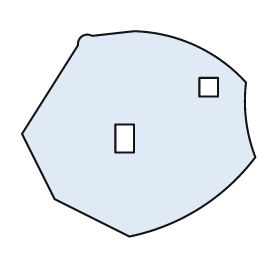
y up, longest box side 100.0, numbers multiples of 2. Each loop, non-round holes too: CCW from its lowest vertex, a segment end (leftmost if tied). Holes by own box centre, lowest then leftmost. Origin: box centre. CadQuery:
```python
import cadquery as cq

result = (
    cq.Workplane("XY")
    .moveTo(-4.0, -44.0)
    .threePointArc((26.0, -32.0), (50.0, -10.0))
    .threePointArc((46.0, 6.0), (46.0, 22.0))
    .threePointArc((24.0, 38.0), (-2.0, 44.0))
    .lineTo(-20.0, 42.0)
    .threePointArc((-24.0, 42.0), (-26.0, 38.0))
    .lineTo(-50.0, 0.0)
    .lineTo(-36.0, -28.0)
    .close()
    .moveTo(-10.0, -8.0)
    .lineTo(-2.0, -8.0)
    .lineTo(-2.0, 4.0)
    .lineTo(-10.0, 4.0)
    .close()
    .moveTo(26.0, 16.0)
    .lineTo(34.0, 16.0)
    .lineTo(34.0, 24.0)
    .lineTo(26.0, 24.0)
    .close()
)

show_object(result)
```